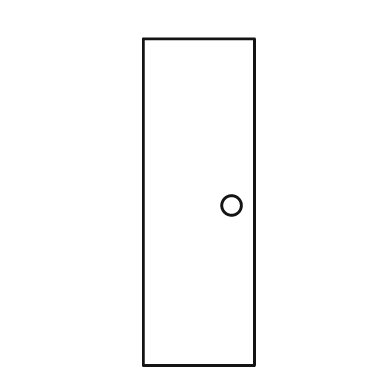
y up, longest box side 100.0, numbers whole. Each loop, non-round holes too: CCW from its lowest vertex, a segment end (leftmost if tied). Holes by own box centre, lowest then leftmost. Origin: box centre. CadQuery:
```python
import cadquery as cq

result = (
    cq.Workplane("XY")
    .moveTo(-17.0, -50.0)
    .lineTo(17.0, -50.0)
    .lineTo(17.0, 50.0)
    .lineTo(-17.0, 50.0)
    .close()
    .moveTo(10.0, -1.0)
    .circle(3.0)
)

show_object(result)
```